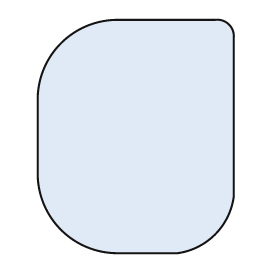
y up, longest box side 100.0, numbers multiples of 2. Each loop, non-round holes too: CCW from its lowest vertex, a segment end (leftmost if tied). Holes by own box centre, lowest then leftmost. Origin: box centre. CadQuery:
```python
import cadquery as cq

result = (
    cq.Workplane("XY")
    .moveTo(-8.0, -50.0)
    .lineTo(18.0, -50.0)
    .threePointArc((34.0, -42.0), (42.0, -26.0))
    .lineTo(42.0, 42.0)
    .threePointArc((40.0, 48.0), (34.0, 50.0))
    .lineTo(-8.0, 50.0)
    .threePointArc((-32.0, 40.0), (-42.0, 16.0))
    .lineTo(-42.0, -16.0)
    .threePointArc((-32.0, -40.0), (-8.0, -50.0))
    .close()
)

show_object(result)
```